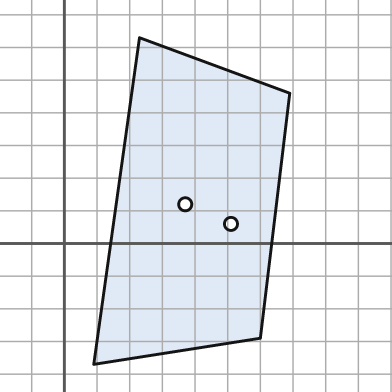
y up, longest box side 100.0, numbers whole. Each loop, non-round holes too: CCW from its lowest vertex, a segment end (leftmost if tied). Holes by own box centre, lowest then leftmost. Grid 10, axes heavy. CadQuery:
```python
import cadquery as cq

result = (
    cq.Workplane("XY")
    .moveTo(9.0, -37.0)
    .lineTo(60.0, -29.0)
    .lineTo(69.0, 46.0)
    .lineTo(23.0, 63.0)
    .close()
    .moveTo(51.0, 6.0)
    .circle(2.0)
    .moveTo(37.0, 12.0)
    .circle(2.0)
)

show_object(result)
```